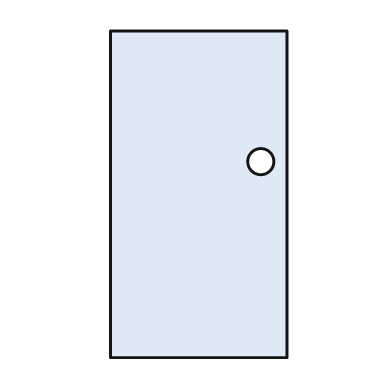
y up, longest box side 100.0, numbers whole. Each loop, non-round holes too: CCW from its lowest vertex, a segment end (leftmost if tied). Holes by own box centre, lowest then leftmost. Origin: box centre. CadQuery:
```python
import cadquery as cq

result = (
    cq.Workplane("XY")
    .moveTo(-27.0, -50.0)
    .lineTo(27.0, -50.0)
    .lineTo(27.0, 50.0)
    .lineTo(-27.0, 50.0)
    .close()
    .moveTo(19.0, 10.0)
    .circle(4.0)
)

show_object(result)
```